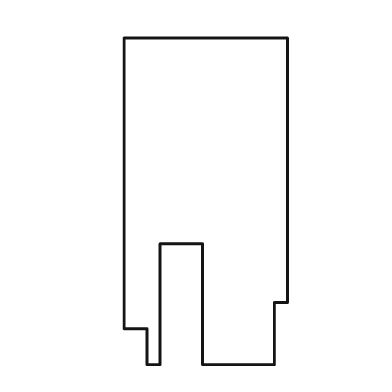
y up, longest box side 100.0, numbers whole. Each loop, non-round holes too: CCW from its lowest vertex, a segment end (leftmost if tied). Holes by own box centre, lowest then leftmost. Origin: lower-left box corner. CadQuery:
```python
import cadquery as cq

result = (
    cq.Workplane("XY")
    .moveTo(7.0, 0.0)
    .lineTo(11.0, 0.0)
    .lineTo(11.0, 37.0)
    .lineTo(24.0, 37.0)
    .lineTo(24.0, 0.0)
    .lineTo(46.0, 0.0)
    .lineTo(46.0, 19.0)
    .lineTo(50.0, 19.0)
    .lineTo(50.0, 100.0)
    .lineTo(0.0, 100.0)
    .lineTo(0.0, 11.0)
    .lineTo(7.0, 11.0)
    .close()
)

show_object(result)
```